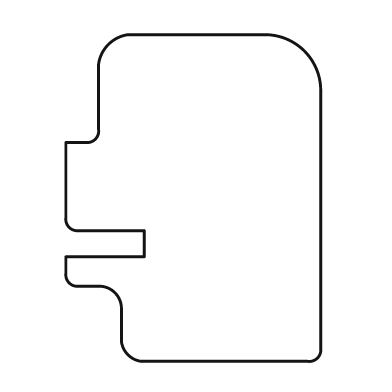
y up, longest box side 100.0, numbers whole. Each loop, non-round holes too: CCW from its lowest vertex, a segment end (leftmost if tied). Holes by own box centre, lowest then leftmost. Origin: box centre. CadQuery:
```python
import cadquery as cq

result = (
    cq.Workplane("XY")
    .moveTo(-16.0, -50.0)
    .lineTo(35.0, -50.0)
    .threePointArc((38.0, -49.0), (39.0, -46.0))
    .lineTo(39.0, 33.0)
    .threePointArc((34.0, 45.0), (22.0, 50.0))
    .lineTo(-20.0, 50.0)
    .threePointArc((-26.0, 47.0), (-29.0, 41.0))
    .lineTo(-29.0, 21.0)
    .threePointArc((-30.0, 18.0), (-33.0, 17.0))
    .lineTo(-39.0, 17.0)
    .lineTo(-39.0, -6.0)
    .threePointArc((-38.0, -9.0), (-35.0, -10.0))
    .lineTo(-15.0, -10.0)
    .lineTo(-15.0, -18.0)
    .lineTo(-39.0, -18.0)
    .lineTo(-39.0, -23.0)
    .threePointArc((-38.0, -26.0), (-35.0, -27.0))
    .lineTo(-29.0, -27.0)
    .threePointArc((-24.0, -29.0), (-22.0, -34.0))
    .lineTo(-22.0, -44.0)
    .threePointArc((-20.0, -48.0), (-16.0, -50.0))
    .close()
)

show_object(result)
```